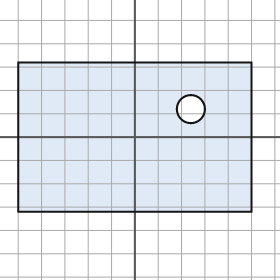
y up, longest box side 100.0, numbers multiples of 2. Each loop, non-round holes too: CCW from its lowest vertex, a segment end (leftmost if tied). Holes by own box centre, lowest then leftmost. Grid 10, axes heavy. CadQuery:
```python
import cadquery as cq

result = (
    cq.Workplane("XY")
    .moveTo(-50.0, -32.0)
    .lineTo(50.0, -32.0)
    .lineTo(50.0, 32.0)
    .lineTo(-50.0, 32.0)
    .close()
    .moveTo(24.0, 12.0)
    .circle(6.0)
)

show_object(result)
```